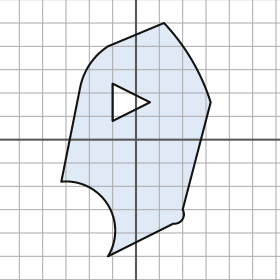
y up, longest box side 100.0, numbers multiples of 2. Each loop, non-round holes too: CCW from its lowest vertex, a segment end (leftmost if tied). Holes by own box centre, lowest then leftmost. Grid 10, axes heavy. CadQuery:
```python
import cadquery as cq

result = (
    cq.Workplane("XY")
    .moveTo(-12.0, -50.0)
    .lineTo(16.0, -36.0)
    .threePointArc((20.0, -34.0), (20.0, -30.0))
    .lineTo(32.0, 16.0)
    .threePointArc((24.0, 34.0), (12.0, 50.0))
    .lineTo(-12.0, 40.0)
    .threePointArc((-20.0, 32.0), (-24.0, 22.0))
    .lineTo(-32.0, -18.0)
    .threePointArc((-12.0, -28.0), (-12.0, -50.0))
    .close()
    .moveTo(-10.0, 8.0)
    .lineTo(6.0, 16.0)
    .lineTo(-10.0, 24.0)
    .close()
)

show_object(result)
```